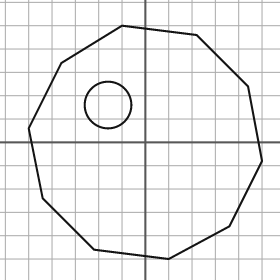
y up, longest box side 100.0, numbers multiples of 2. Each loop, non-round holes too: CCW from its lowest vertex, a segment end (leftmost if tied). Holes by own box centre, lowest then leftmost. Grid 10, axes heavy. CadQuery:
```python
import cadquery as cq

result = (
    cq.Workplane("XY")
    .moveTo(10.0, -50.0)
    .lineTo(36.0, -36.0)
    .lineTo(50.0, -8.0)
    .lineTo(44.0, 24.0)
    .lineTo(22.0, 46.0)
    .lineTo(-10.0, 50.0)
    .lineTo(-36.0, 34.0)
    .lineTo(-50.0, 6.0)
    .lineTo(-44.0, -24.0)
    .lineTo(-22.0, -46.0)
    .close()
    .moveTo(-16.0, 16.0)
    .circle(10.0)
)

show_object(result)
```